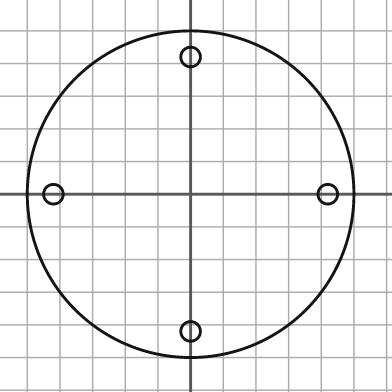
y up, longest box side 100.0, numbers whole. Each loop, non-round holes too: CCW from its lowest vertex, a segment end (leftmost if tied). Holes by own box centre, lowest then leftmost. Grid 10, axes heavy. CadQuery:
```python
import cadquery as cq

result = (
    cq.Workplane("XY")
    .moveTo(0.0, 0.0)
    .circle(50.0)
    .moveTo(0.0, -42.0)
    .circle(3.0)
    .moveTo(-42.0, 0.0)
    .circle(3.0)
    .moveTo(42.0, 0.0)
    .circle(3.0)
    .moveTo(0.0, 42.0)
    .circle(3.0)
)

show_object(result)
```